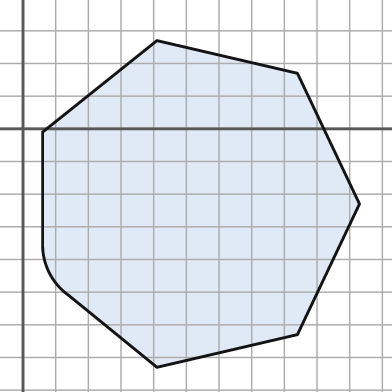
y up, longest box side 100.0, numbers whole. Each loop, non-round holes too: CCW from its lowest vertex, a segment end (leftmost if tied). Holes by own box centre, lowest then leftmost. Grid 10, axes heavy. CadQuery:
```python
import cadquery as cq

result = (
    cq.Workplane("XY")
    .moveTo(41.0, -73.0)
    .lineTo(84.0, -63.0)
    .lineTo(103.0, -23.0)
    .lineTo(84.0, 17.0)
    .lineTo(41.0, 27.0)
    .lineTo(6.0, -1.0)
    .lineTo(6.0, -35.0)
    .threePointArc((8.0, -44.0), (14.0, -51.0))
    .close()
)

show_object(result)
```